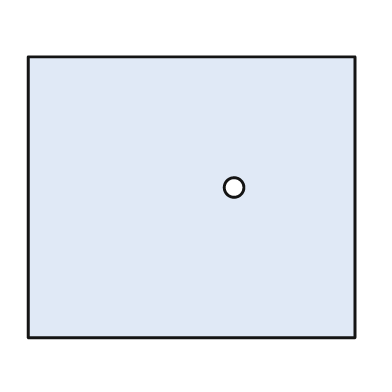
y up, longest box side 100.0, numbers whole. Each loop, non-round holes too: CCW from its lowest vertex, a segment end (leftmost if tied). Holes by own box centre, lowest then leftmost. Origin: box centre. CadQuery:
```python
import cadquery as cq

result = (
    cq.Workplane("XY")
    .moveTo(-50.0, -43.0)
    .lineTo(50.0, -43.0)
    .lineTo(50.0, 43.0)
    .lineTo(-50.0, 43.0)
    .close()
    .moveTo(13.0, 3.0)
    .circle(3.0)
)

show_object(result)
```